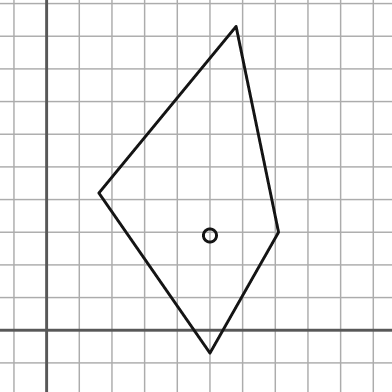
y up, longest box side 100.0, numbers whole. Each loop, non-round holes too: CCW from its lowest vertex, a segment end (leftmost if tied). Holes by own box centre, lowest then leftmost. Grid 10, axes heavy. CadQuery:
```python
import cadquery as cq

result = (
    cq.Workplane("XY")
    .moveTo(50.0, -7.0)
    .lineTo(71.0, 30.0)
    .lineTo(58.0, 93.0)
    .lineTo(16.0, 42.0)
    .close()
    .moveTo(50.0, 29.0)
    .circle(2.0)
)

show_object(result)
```